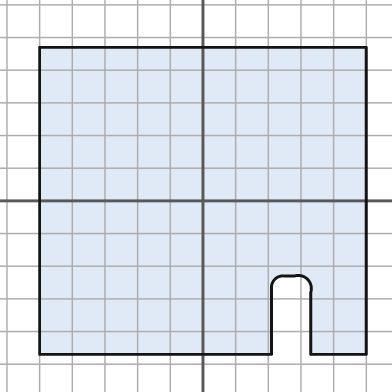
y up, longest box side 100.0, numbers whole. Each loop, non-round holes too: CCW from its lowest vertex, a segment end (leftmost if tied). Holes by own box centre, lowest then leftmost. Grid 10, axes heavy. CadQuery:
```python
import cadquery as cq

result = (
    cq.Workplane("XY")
    .moveTo(-50.0, -47.0)
    .lineTo(21.0, -47.0)
    .lineTo(21.0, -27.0)
    .threePointArc((22.0, -24.0), (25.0, -23.0))
    .lineTo(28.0, -23.0)
    .threePointArc((32.0, -24.0), (33.0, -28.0))
    .lineTo(33.0, -47.0)
    .lineTo(50.0, -47.0)
    .lineTo(50.0, 47.0)
    .lineTo(-50.0, 47.0)
    .close()
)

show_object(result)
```